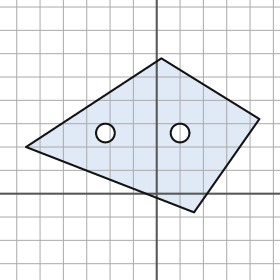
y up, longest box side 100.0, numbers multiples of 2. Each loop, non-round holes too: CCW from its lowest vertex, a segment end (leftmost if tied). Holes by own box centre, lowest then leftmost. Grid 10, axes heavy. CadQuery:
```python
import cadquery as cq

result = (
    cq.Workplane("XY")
    .moveTo(16.0, -8.0)
    .lineTo(44.0, 32.0)
    .lineTo(2.0, 58.0)
    .lineTo(-56.0, 20.0)
    .close()
    .moveTo(-22.0, 26.0)
    .circle(4.0)
    .moveTo(10.0, 26.0)
    .circle(4.0)
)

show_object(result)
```